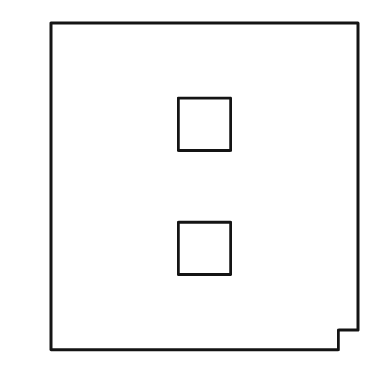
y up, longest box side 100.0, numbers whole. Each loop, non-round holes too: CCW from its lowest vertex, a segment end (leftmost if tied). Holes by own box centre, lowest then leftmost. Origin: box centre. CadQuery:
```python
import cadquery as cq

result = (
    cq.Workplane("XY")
    .moveTo(-47.0, -50.0)
    .lineTo(41.0, -50.0)
    .lineTo(41.0, -44.0)
    .lineTo(47.0, -44.0)
    .lineTo(47.0, 50.0)
    .lineTo(-47.0, 50.0)
    .close()
    .moveTo(-8.0, -27.0)
    .lineTo(8.0, -27.0)
    .lineTo(8.0, -11.0)
    .lineTo(-8.0, -11.0)
    .close()
    .moveTo(-8.0, 11.0)
    .lineTo(8.0, 11.0)
    .lineTo(8.0, 27.0)
    .lineTo(-8.0, 27.0)
    .close()
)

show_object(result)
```